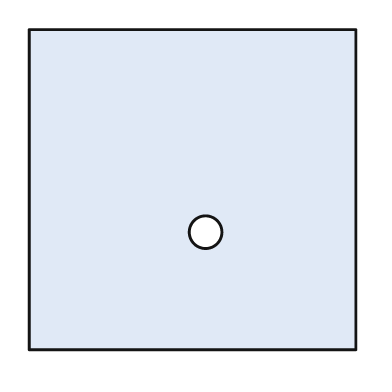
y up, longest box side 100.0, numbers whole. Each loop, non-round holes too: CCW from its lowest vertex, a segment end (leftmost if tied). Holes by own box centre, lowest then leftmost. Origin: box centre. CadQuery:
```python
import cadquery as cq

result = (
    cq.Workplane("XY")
    .moveTo(-50.0, -49.0)
    .lineTo(50.0, -49.0)
    .lineTo(50.0, 49.0)
    .lineTo(-50.0, 49.0)
    .close()
    .moveTo(4.0, -13.0)
    .circle(5.0)
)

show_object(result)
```